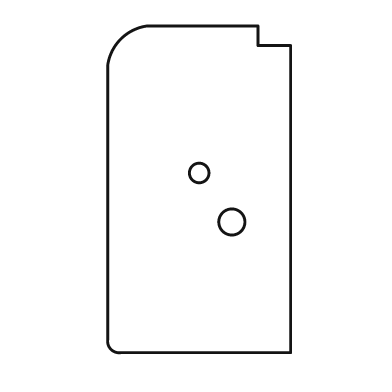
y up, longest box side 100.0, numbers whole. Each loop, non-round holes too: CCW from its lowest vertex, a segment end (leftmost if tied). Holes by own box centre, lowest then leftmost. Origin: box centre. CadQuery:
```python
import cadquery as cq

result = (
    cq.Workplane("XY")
    .moveTo(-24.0, -50.0)
    .lineTo(28.0, -50.0)
    .lineTo(28.0, 44.0)
    .lineTo(18.0, 44.0)
    .lineTo(18.0, 50.0)
    .lineTo(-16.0, 50.0)
    .threePointArc((-24.0, 46.0), (-28.0, 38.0))
    .lineTo(-28.0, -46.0)
    .threePointArc((-27.0, -49.0), (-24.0, -50.0))
    .close()
    .moveTo(10.0, -10.0)
    .circle(4.0)
    .moveTo(0.0, 5.0)
    .circle(3.0)
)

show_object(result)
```